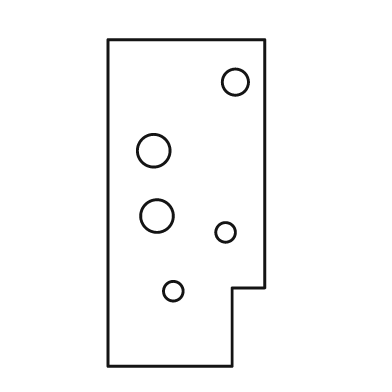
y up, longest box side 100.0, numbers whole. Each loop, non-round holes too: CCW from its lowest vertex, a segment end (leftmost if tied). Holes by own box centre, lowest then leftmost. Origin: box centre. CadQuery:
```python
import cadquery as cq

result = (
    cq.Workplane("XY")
    .moveTo(-24.0, -50.0)
    .lineTo(14.0, -50.0)
    .lineTo(14.0, -26.0)
    .lineTo(24.0, -26.0)
    .lineTo(24.0, 50.0)
    .lineTo(-24.0, 50.0)
    .close()
    .moveTo(-4.0, -27.0)
    .circle(3.0)
    .moveTo(12.0, -9.0)
    .circle(3.0)
    .moveTo(-9.0, -4.0)
    .circle(5.0)
    .moveTo(-10.0, 16.0)
    .circle(5.0)
    .moveTo(15.0, 37.0)
    .circle(4.0)
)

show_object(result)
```